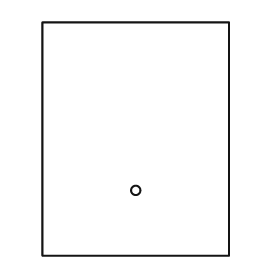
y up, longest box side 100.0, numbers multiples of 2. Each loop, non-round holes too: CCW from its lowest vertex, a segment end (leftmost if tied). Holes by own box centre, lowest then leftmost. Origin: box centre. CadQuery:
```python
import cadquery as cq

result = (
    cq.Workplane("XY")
    .moveTo(-40.0, -50.0)
    .lineTo(40.0, -50.0)
    .lineTo(40.0, 50.0)
    .lineTo(-40.0, 50.0)
    .close()
    .moveTo(0.0, -22.0)
    .circle(2.0)
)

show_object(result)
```